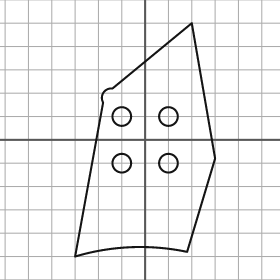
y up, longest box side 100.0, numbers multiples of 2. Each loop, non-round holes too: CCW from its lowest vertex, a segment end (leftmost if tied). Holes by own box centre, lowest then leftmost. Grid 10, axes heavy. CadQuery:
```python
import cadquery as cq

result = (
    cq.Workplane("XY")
    .moveTo(-30.0, -50.0)
    .threePointArc((-6.0, -46.0), (18.0, -48.0))
    .lineTo(30.0, -8.0)
    .lineTo(20.0, 50.0)
    .lineTo(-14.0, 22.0)
    .threePointArc((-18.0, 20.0), (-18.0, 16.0))
    .close()
    .moveTo(-10.0, -10.0)
    .circle(4.0)
    .moveTo(10.0, -10.0)
    .circle(4.0)
    .moveTo(-10.0, 10.0)
    .circle(4.0)
    .moveTo(10.0, 10.0)
    .circle(4.0)
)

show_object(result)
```